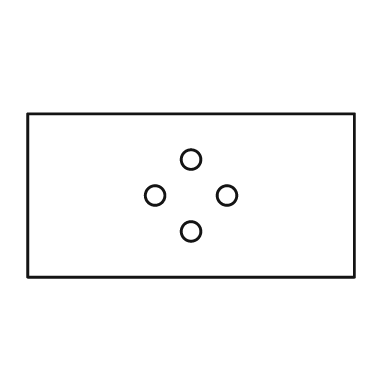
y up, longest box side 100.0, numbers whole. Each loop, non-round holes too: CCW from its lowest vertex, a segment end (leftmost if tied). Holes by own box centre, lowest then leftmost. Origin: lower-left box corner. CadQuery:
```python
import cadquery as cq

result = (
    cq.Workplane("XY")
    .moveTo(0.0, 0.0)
    .lineTo(100.0, 0.0)
    .lineTo(100.0, 50.0)
    .lineTo(0.0, 50.0)
    .close()
    .moveTo(50.0, 14.0)
    .circle(3.0)
    .moveTo(39.0, 25.0)
    .circle(3.0)
    .moveTo(61.0, 25.0)
    .circle(3.0)
    .moveTo(50.0, 36.0)
    .circle(3.0)
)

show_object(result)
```